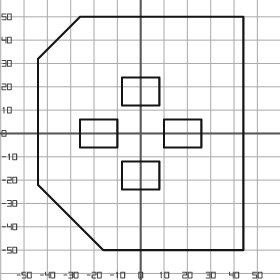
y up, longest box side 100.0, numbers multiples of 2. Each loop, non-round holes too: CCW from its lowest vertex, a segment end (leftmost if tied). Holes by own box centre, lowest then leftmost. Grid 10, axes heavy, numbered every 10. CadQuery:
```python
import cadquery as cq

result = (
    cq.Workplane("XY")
    .moveTo(-16.0, -50.0)
    .lineTo(44.0, -50.0)
    .lineTo(44.0, 50.0)
    .lineTo(-26.0, 50.0)
    .lineTo(-44.0, 32.0)
    .lineTo(-44.0, -22.0)
    .close()
    .moveTo(-8.0, -24.0)
    .lineTo(8.0, -24.0)
    .lineTo(8.0, -12.0)
    .lineTo(-8.0, -12.0)
    .close()
    .moveTo(-26.0, -6.0)
    .lineTo(-10.0, -6.0)
    .lineTo(-10.0, 6.0)
    .lineTo(-26.0, 6.0)
    .close()
    .moveTo(10.0, -6.0)
    .lineTo(26.0, -6.0)
    .lineTo(26.0, 6.0)
    .lineTo(10.0, 6.0)
    .close()
    .moveTo(-8.0, 12.0)
    .lineTo(8.0, 12.0)
    .lineTo(8.0, 24.0)
    .lineTo(-8.0, 24.0)
    .close()
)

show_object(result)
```